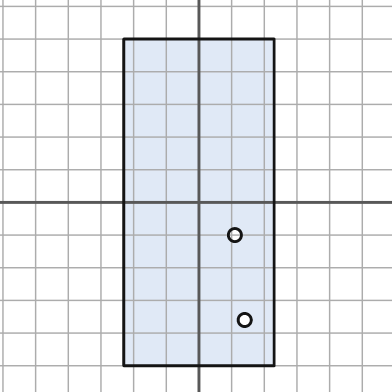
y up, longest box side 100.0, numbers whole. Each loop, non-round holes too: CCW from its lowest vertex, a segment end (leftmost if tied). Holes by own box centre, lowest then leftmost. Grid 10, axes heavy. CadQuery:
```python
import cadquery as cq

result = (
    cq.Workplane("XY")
    .moveTo(-23.0, -50.0)
    .lineTo(23.0, -50.0)
    .lineTo(23.0, 50.0)
    .lineTo(-23.0, 50.0)
    .close()
    .moveTo(14.0, -36.0)
    .circle(2.0)
    .moveTo(11.0, -10.0)
    .circle(2.0)
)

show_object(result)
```